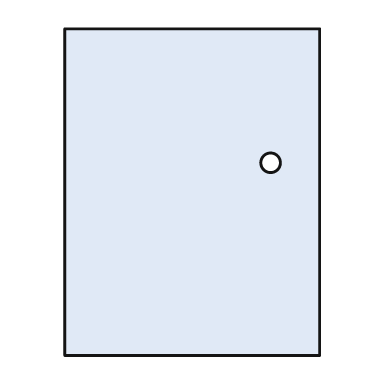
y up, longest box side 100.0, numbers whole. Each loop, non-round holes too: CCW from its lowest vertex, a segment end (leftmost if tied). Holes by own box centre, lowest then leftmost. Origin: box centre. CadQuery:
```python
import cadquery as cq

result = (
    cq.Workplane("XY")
    .moveTo(-39.0, -50.0)
    .lineTo(39.0, -50.0)
    .lineTo(39.0, 50.0)
    .lineTo(-39.0, 50.0)
    .close()
    .moveTo(24.0, 9.0)
    .circle(3.0)
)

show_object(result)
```